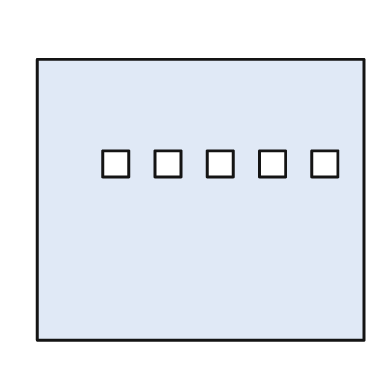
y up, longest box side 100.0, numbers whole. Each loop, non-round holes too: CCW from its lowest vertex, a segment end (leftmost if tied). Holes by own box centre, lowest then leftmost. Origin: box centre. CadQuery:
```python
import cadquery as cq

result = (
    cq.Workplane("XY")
    .moveTo(-50.0, -43.0)
    .lineTo(50.0, -43.0)
    .lineTo(50.0, 43.0)
    .lineTo(-50.0, 43.0)
    .close()
    .moveTo(-30.0, 7.0)
    .lineTo(-22.0, 7.0)
    .lineTo(-22.0, 15.0)
    .lineTo(-30.0, 15.0)
    .close()
    .moveTo(-14.0, 7.0)
    .lineTo(-6.0, 7.0)
    .lineTo(-6.0, 15.0)
    .lineTo(-14.0, 15.0)
    .close()
    .moveTo(2.0, 7.0)
    .lineTo(10.0, 7.0)
    .lineTo(10.0, 15.0)
    .lineTo(2.0, 15.0)
    .close()
    .moveTo(18.0, 7.0)
    .lineTo(26.0, 7.0)
    .lineTo(26.0, 15.0)
    .lineTo(18.0, 15.0)
    .close()
    .moveTo(34.0, 7.0)
    .lineTo(42.0, 7.0)
    .lineTo(42.0, 15.0)
    .lineTo(34.0, 15.0)
    .close()
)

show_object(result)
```